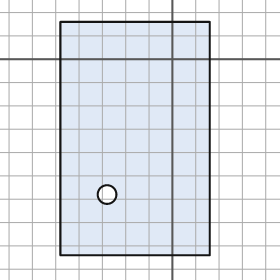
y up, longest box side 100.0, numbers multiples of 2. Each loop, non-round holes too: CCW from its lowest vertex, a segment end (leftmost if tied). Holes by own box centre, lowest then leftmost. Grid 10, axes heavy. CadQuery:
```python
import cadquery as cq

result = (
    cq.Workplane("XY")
    .moveTo(-48.0, -84.0)
    .lineTo(16.0, -84.0)
    .lineTo(16.0, 16.0)
    .lineTo(-48.0, 16.0)
    .close()
    .moveTo(-28.0, -58.0)
    .circle(4.0)
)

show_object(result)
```